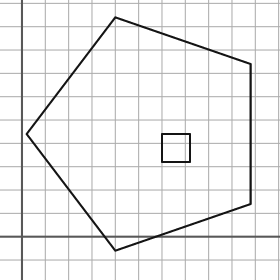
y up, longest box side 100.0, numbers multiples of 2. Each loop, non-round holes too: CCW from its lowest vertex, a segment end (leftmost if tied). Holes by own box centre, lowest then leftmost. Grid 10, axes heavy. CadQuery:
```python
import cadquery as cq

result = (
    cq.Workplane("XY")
    .moveTo(40.0, -6.0)
    .lineTo(98.0, 14.0)
    .lineTo(98.0, 74.0)
    .lineTo(40.0, 94.0)
    .lineTo(2.0, 44.0)
    .close()
    .moveTo(60.0, 32.0)
    .lineTo(72.0, 32.0)
    .lineTo(72.0, 44.0)
    .lineTo(60.0, 44.0)
    .close()
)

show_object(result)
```